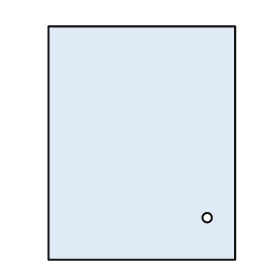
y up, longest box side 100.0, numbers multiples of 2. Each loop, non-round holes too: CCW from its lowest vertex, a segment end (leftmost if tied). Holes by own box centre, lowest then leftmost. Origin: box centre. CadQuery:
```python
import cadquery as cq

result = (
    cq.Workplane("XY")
    .moveTo(-40.0, -50.0)
    .lineTo(40.0, -50.0)
    .lineTo(40.0, 50.0)
    .lineTo(-40.0, 50.0)
    .close()
    .moveTo(28.0, -32.0)
    .circle(2.0)
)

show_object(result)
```